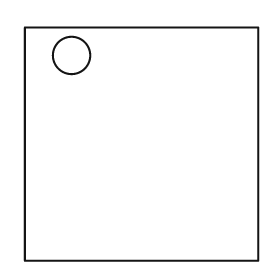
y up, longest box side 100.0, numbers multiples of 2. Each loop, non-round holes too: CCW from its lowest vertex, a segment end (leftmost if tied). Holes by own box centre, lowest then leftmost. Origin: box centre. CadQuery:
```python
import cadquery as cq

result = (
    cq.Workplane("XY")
    .moveTo(-50.0, -50.0)
    .lineTo(50.0, -50.0)
    .lineTo(50.0, 50.0)
    .lineTo(-50.0, 50.0)
    .close()
    .moveTo(-30.0, 38.0)
    .circle(8.0)
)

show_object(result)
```